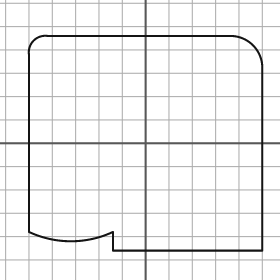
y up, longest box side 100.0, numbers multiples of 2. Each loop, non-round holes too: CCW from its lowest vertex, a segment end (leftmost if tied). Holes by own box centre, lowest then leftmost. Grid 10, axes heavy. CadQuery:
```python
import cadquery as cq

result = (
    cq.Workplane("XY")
    .moveTo(-14.0, -46.0)
    .lineTo(50.0, -46.0)
    .lineTo(50.0, 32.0)
    .threePointArc((46.0, 42.0), (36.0, 46.0))
    .lineTo(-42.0, 46.0)
    .threePointArc((-48.0, 44.0), (-50.0, 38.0))
    .lineTo(-50.0, -38.0)
    .threePointArc((-32.0, -42.0), (-14.0, -38.0))
    .close()
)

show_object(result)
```